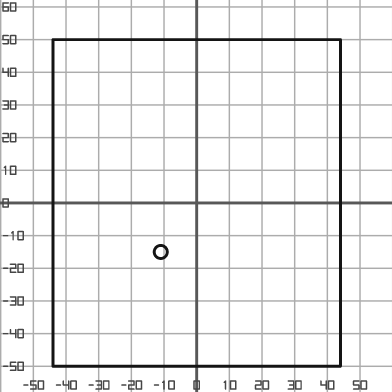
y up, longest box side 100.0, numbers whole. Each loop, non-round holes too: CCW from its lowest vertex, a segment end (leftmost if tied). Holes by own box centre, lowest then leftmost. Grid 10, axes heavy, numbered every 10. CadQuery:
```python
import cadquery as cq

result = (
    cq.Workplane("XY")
    .moveTo(-44.0, -50.0)
    .lineTo(44.0, -50.0)
    .lineTo(44.0, 50.0)
    .lineTo(-44.0, 50.0)
    .close()
    .moveTo(-11.0, -15.0)
    .circle(2.0)
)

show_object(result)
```